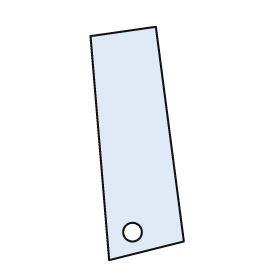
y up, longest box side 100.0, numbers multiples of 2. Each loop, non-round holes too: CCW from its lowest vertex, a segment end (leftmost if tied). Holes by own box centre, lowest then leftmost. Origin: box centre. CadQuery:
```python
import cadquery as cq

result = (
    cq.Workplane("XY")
    .moveTo(-12.0, -50.0)
    .lineTo(20.0, -42.0)
    .lineTo(8.0, 50.0)
    .lineTo(-20.0, 46.0)
    .close()
    .moveTo(-2.0, -38.0)
    .circle(4.0)
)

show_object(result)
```